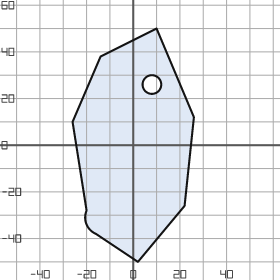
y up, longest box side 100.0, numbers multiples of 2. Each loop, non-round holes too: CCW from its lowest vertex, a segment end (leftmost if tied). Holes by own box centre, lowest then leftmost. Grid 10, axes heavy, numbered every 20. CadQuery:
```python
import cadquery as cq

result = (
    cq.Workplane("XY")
    .moveTo(2.0, -50.0)
    .lineTo(22.0, -26.0)
    .lineTo(26.0, 12.0)
    .lineTo(10.0, 50.0)
    .lineTo(-14.0, 38.0)
    .lineTo(-26.0, 10.0)
    .lineTo(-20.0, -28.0)
    .threePointArc((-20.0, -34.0), (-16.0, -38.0))
    .close()
    .moveTo(8.0, 26.0)
    .circle(4.0)
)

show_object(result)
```